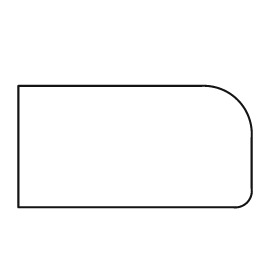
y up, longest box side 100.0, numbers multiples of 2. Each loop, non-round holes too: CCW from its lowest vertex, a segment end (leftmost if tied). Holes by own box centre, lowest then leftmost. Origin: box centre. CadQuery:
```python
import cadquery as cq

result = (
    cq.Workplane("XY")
    .moveTo(-50.0, -26.0)
    .lineTo(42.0, -26.0)
    .threePointArc((48.0, -24.0), (50.0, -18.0))
    .lineTo(50.0, 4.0)
    .threePointArc((44.0, 20.0), (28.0, 26.0))
    .lineTo(-50.0, 26.0)
    .close()
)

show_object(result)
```